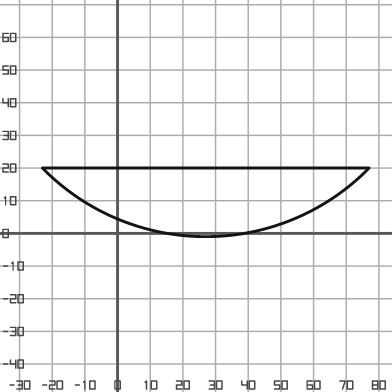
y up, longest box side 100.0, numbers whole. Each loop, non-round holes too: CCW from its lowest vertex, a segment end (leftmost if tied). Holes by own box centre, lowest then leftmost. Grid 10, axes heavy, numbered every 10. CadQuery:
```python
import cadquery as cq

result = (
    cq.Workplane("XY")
    .moveTo(-23.0, 20.0)
    .threePointArc((27.0, -1.0), (77.0, 20.0))
    .close()
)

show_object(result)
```